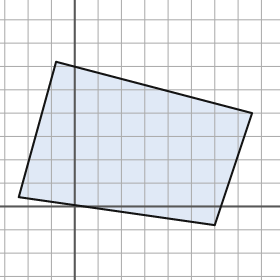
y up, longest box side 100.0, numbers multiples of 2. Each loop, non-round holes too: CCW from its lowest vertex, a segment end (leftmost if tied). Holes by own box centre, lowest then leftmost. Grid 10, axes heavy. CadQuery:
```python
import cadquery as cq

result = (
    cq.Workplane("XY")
    .moveTo(60.0, -8.0)
    .lineTo(76.0, 40.0)
    .lineTo(-8.0, 62.0)
    .lineTo(-24.0, 4.0)
    .close()
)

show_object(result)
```